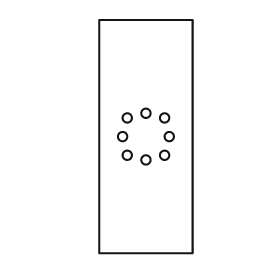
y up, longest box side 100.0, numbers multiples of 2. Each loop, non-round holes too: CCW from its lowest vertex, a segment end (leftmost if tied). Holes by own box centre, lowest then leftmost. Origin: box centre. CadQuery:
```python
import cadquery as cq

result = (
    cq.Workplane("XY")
    .moveTo(-20.0, -50.0)
    .lineTo(20.0, -50.0)
    .lineTo(20.0, 50.0)
    .lineTo(-20.0, 50.0)
    .close()
    .moveTo(0.0, -10.0)
    .circle(2.0)
    .moveTo(-8.0, -8.0)
    .circle(2.0)
    .moveTo(8.0, -8.0)
    .circle(2.0)
    .moveTo(-10.0, 0.0)
    .circle(2.0)
    .moveTo(10.0, 0.0)
    .circle(2.0)
    .moveTo(-8.0, 8.0)
    .circle(2.0)
    .moveTo(8.0, 8.0)
    .circle(2.0)
    .moveTo(0.0, 10.0)
    .circle(2.0)
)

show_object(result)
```